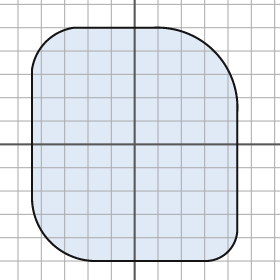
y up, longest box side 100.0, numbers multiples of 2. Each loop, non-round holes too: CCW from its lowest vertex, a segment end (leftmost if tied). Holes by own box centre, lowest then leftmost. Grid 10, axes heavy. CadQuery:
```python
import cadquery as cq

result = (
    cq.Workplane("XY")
    .moveTo(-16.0, -50.0)
    .lineTo(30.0, -50.0)
    .threePointArc((40.0, -46.0), (44.0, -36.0))
    .lineTo(44.0, 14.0)
    .threePointArc((34.0, 40.0), (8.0, 50.0))
    .lineTo(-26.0, 50.0)
    .threePointArc((-38.0, 44.0), (-44.0, 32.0))
    .lineTo(-44.0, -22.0)
    .threePointArc((-36.0, -42.0), (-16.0, -50.0))
    .close()
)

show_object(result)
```